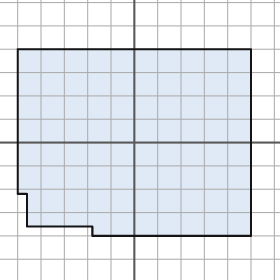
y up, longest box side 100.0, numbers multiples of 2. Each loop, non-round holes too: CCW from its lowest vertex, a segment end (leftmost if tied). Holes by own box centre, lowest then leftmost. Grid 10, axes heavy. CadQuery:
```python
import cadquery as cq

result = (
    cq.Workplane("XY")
    .moveTo(-18.0, -40.0)
    .lineTo(50.0, -40.0)
    .lineTo(50.0, 40.0)
    .lineTo(-50.0, 40.0)
    .lineTo(-50.0, -22.0)
    .lineTo(-46.0, -22.0)
    .lineTo(-46.0, -36.0)
    .lineTo(-18.0, -36.0)
    .close()
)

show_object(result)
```